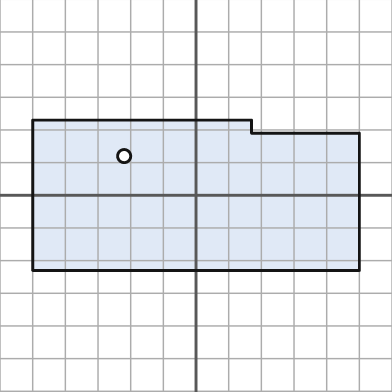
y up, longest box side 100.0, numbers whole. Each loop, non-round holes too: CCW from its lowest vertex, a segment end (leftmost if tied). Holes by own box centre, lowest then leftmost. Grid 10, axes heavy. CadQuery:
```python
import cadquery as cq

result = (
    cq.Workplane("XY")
    .moveTo(-50.0, -23.0)
    .lineTo(50.0, -23.0)
    .lineTo(50.0, 19.0)
    .lineTo(17.0, 19.0)
    .lineTo(17.0, 23.0)
    .lineTo(-50.0, 23.0)
    .close()
    .moveTo(-22.0, 12.0)
    .circle(2.0)
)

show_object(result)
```